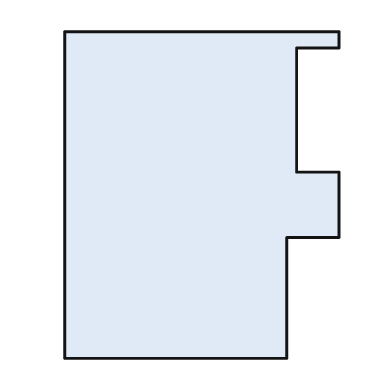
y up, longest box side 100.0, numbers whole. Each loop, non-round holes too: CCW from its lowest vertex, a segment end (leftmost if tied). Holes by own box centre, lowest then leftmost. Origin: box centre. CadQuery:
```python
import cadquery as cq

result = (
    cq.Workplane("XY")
    .moveTo(-42.0, -50.0)
    .lineTo(26.0, -50.0)
    .lineTo(26.0, -13.0)
    .lineTo(42.0, -13.0)
    .lineTo(42.0, 7.0)
    .lineTo(29.0, 7.0)
    .lineTo(29.0, 45.0)
    .lineTo(42.0, 45.0)
    .lineTo(42.0, 50.0)
    .lineTo(-42.0, 50.0)
    .close()
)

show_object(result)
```